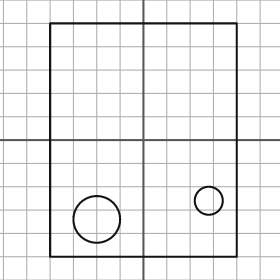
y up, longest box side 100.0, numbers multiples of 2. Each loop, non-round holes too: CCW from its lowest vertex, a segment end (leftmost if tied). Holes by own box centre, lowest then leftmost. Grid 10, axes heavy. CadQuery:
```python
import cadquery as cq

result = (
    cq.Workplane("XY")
    .moveTo(-40.0, -50.0)
    .lineTo(40.0, -50.0)
    .lineTo(40.0, 50.0)
    .lineTo(-40.0, 50.0)
    .close()
    .moveTo(-20.0, -34.0)
    .circle(10.0)
    .moveTo(28.0, -26.0)
    .circle(6.0)
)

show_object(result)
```